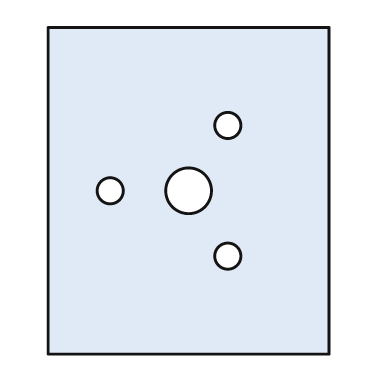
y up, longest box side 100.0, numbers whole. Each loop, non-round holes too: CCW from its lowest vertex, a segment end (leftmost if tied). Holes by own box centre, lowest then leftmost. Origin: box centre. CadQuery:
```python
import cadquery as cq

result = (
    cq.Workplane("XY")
    .moveTo(-43.0, -50.0)
    .lineTo(43.0, -50.0)
    .lineTo(43.0, 50.0)
    .lineTo(-43.0, 50.0)
    .close()
    .moveTo(12.0, -20.0)
    .circle(4.0)
    .moveTo(-24.0, 0.0)
    .circle(4.0)
    .moveTo(0.0, 0.0)
    .circle(7.0)
    .moveTo(12.0, 20.0)
    .circle(4.0)
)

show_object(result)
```